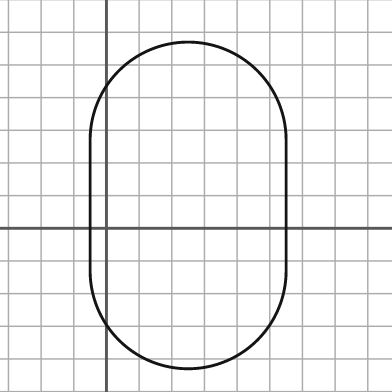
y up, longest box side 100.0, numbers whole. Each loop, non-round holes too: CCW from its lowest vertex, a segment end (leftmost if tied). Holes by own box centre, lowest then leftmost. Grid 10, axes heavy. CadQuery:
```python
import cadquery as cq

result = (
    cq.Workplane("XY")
    .moveTo(-5.0, -13.0)
    .threePointArc((25.0, -43.0), (55.0, -13.0))
    .lineTo(55.0, 27.0)
    .threePointArc((25.0, 57.0), (-5.0, 27.0))
    .close()
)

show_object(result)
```